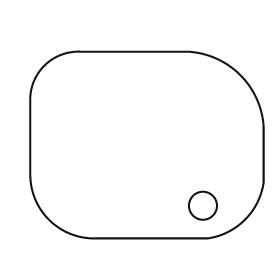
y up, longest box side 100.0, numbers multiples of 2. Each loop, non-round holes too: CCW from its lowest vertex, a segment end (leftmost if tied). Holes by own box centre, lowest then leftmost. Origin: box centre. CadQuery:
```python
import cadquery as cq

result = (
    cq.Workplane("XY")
    .moveTo(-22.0, -40.0)
    .lineTo(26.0, -40.0)
    .threePointArc((42.0, -32.0), (50.0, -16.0))
    .lineTo(50.0, 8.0)
    .threePointArc((40.0, 30.0), (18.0, 40.0))
    .lineTo(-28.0, 40.0)
    .threePointArc((-44.0, 34.0), (-50.0, 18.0))
    .lineTo(-50.0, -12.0)
    .threePointArc((-42.0, -32.0), (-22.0, -40.0))
    .close()
    .moveTo(24.0, -26.0)
    .circle(6.0)
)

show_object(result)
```